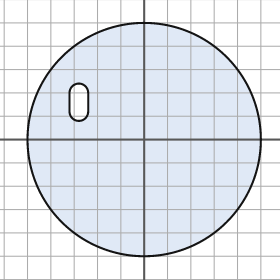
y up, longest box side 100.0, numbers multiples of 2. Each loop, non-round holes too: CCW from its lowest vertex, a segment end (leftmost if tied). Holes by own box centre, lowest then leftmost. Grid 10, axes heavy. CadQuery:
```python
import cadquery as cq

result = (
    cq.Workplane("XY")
    .moveTo(0.0, 0.0)
    .circle(50.0)
    .moveTo(-32.0, 12.0)
    .threePointArc((-28.0, 8.0), (-24.0, 12.0))
    .lineTo(-24.0, 20.0)
    .threePointArc((-28.0, 24.0), (-32.0, 20.0))
    .close()
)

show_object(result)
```